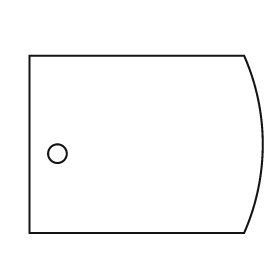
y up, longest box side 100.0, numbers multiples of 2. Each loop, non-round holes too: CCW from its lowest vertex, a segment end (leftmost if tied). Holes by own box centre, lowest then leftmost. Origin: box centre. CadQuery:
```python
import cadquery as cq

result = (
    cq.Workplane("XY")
    .moveTo(-50.0, -38.0)
    .lineTo(42.0, -38.0)
    .threePointArc((50.0, 0.0), (42.0, 38.0))
    .lineTo(-50.0, 38.0)
    .close()
    .moveTo(-38.0, -4.0)
    .circle(4.0)
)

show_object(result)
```